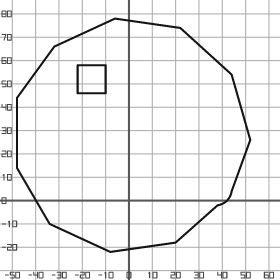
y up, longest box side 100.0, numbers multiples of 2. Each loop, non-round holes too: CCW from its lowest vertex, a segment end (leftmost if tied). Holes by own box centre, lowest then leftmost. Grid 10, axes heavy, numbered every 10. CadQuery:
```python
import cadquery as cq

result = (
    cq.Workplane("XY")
    .moveTo(-8.0, -22.0)
    .lineTo(20.0, -18.0)
    .lineTo(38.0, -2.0)
    .threePointArc((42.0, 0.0), (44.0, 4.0))
    .lineTo(52.0, 26.0)
    .lineTo(44.0, 54.0)
    .lineTo(22.0, 74.0)
    .lineTo(-6.0, 78.0)
    .lineTo(-32.0, 66.0)
    .lineTo(-48.0, 44.0)
    .lineTo(-48.0, 14.0)
    .lineTo(-34.0, -10.0)
    .close()
    .moveTo(-22.0, 46.0)
    .lineTo(-10.0, 46.0)
    .lineTo(-10.0, 58.0)
    .lineTo(-22.0, 58.0)
    .close()
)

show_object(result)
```